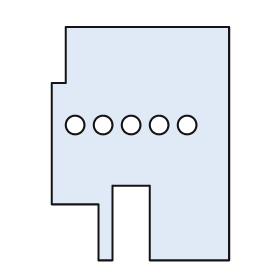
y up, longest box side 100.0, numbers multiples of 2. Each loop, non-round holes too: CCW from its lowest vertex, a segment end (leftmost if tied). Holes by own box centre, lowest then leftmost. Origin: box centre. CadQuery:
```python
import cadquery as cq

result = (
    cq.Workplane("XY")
    .moveTo(-18.0, -50.0)
    .lineTo(-12.0, -50.0)
    .lineTo(-12.0, -18.0)
    .lineTo(4.0, -18.0)
    .lineTo(4.0, -50.0)
    .lineTo(38.0, -50.0)
    .lineTo(38.0, 50.0)
    .lineTo(-32.0, 50.0)
    .lineTo(-32.0, 26.0)
    .lineTo(-38.0, 26.0)
    .lineTo(-38.0, -26.0)
    .lineTo(-18.0, -26.0)
    .close()
    .moveTo(-28.0, 8.0)
    .circle(4.0)
    .moveTo(-16.0, 8.0)
    .circle(4.0)
    .moveTo(-4.0, 8.0)
    .circle(4.0)
    .moveTo(8.0, 8.0)
    .circle(4.0)
    .moveTo(20.0, 8.0)
    .circle(4.0)
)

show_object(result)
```